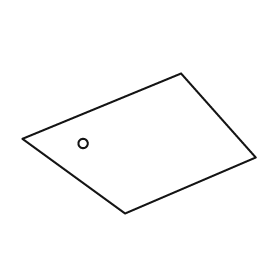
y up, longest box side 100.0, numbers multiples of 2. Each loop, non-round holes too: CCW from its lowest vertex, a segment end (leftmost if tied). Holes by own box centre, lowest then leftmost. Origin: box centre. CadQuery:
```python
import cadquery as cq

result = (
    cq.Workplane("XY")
    .moveTo(-6.0, -30.0)
    .lineTo(50.0, -6.0)
    .lineTo(18.0, 30.0)
    .lineTo(-50.0, 2.0)
    .close()
    .moveTo(-24.0, 0.0)
    .circle(2.0)
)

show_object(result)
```